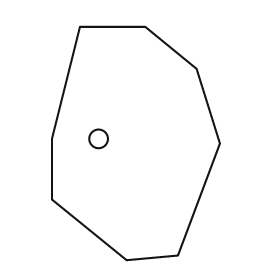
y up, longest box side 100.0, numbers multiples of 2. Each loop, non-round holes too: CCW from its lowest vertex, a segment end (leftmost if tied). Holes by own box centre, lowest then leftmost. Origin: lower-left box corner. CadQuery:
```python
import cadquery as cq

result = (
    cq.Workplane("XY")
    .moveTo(32.0, 0.0)
    .lineTo(54.0, 2.0)
    .lineTo(72.0, 50.0)
    .lineTo(62.0, 82.0)
    .lineTo(40.0, 100.0)
    .lineTo(12.0, 100.0)
    .lineTo(0.0, 52.0)
    .lineTo(0.0, 26.0)
    .close()
    .moveTo(20.0, 52.0)
    .circle(4.0)
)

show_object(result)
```